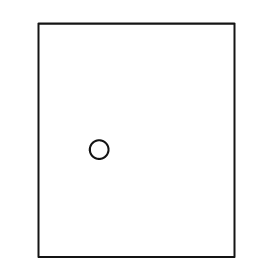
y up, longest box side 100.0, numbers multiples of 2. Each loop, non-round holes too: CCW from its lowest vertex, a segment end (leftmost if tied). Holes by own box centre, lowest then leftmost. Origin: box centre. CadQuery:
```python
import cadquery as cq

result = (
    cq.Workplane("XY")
    .moveTo(-42.0, -50.0)
    .lineTo(42.0, -50.0)
    .lineTo(42.0, 50.0)
    .lineTo(-42.0, 50.0)
    .close()
    .moveTo(-16.0, -4.0)
    .circle(4.0)
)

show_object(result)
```